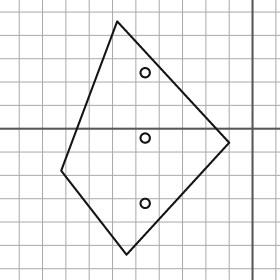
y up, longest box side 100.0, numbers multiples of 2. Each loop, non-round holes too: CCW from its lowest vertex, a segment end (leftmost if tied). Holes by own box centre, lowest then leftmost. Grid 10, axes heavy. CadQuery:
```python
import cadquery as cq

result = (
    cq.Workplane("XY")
    .moveTo(-54.0, -54.0)
    .lineTo(-10.0, -6.0)
    .lineTo(-58.0, 46.0)
    .lineTo(-82.0, -18.0)
    .close()
    .moveTo(-46.0, -32.0)
    .circle(2.0)
    .moveTo(-46.0, -4.0)
    .circle(2.0)
    .moveTo(-46.0, 24.0)
    .circle(2.0)
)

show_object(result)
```